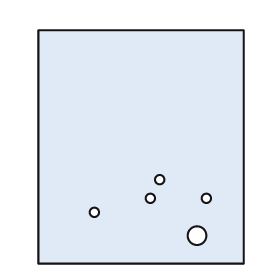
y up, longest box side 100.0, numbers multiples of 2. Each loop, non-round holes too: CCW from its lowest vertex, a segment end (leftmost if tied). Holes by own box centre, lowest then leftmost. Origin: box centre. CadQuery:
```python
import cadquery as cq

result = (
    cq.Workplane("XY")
    .moveTo(-44.0, -50.0)
    .lineTo(44.0, -50.0)
    .lineTo(44.0, 50.0)
    .lineTo(-44.0, 50.0)
    .close()
    .moveTo(24.0, -38.0)
    .circle(4.0)
    .moveTo(-20.0, -28.0)
    .circle(2.0)
    .moveTo(4.0, -22.0)
    .circle(2.0)
    .moveTo(28.0, -22.0)
    .circle(2.0)
    .moveTo(8.0, -14.0)
    .circle(2.0)
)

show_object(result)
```